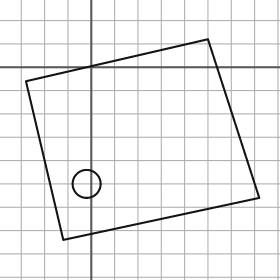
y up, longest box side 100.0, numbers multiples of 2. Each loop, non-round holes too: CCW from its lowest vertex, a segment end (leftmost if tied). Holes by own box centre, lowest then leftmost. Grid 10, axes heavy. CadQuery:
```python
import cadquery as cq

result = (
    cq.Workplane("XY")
    .moveTo(-12.0, -74.0)
    .lineTo(72.0, -56.0)
    .lineTo(50.0, 12.0)
    .lineTo(-28.0, -6.0)
    .close()
    .moveTo(-2.0, -50.0)
    .circle(6.0)
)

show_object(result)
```